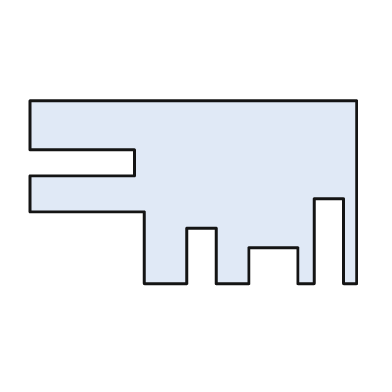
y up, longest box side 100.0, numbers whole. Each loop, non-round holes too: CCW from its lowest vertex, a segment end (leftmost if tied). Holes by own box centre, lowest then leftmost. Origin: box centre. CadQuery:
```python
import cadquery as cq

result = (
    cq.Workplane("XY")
    .moveTo(-15.0, -28.0)
    .lineTo(-2.0, -28.0)
    .lineTo(-2.0, -11.0)
    .lineTo(7.0, -11.0)
    .lineTo(7.0, -28.0)
    .lineTo(17.0, -28.0)
    .lineTo(17.0, -17.0)
    .lineTo(32.0, -17.0)
    .lineTo(32.0, -28.0)
    .lineTo(37.0, -28.0)
    .lineTo(37.0, -2.0)
    .lineTo(46.0, -2.0)
    .lineTo(46.0, -28.0)
    .lineTo(50.0, -28.0)
    .lineTo(50.0, 28.0)
    .lineTo(-50.0, 28.0)
    .lineTo(-50.0, 13.0)
    .lineTo(-18.0, 13.0)
    .lineTo(-18.0, 5.0)
    .lineTo(-50.0, 5.0)
    .lineTo(-50.0, -6.0)
    .lineTo(-15.0, -6.0)
    .close()
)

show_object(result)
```